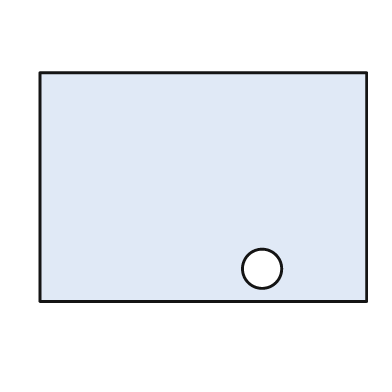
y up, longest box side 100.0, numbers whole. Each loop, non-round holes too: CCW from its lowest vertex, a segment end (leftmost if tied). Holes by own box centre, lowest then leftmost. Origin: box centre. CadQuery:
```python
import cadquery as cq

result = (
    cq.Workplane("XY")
    .moveTo(-50.0, -35.0)
    .lineTo(50.0, -35.0)
    .lineTo(50.0, 35.0)
    .lineTo(-50.0, 35.0)
    .close()
    .moveTo(18.0, -25.0)
    .circle(6.0)
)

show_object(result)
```